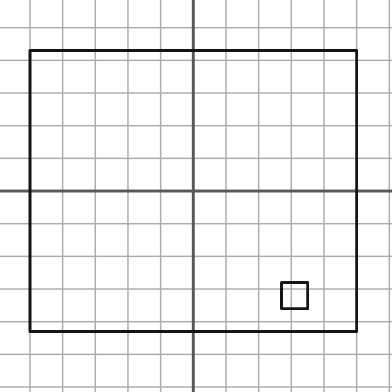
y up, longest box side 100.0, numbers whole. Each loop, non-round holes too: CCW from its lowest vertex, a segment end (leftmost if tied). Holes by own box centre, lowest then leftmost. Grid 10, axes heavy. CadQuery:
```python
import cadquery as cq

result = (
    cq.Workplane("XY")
    .moveTo(-50.0, -43.0)
    .lineTo(50.0, -43.0)
    .lineTo(50.0, 43.0)
    .lineTo(-50.0, 43.0)
    .close()
    .moveTo(27.0, -36.0)
    .lineTo(35.0, -36.0)
    .lineTo(35.0, -28.0)
    .lineTo(27.0, -28.0)
    .close()
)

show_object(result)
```